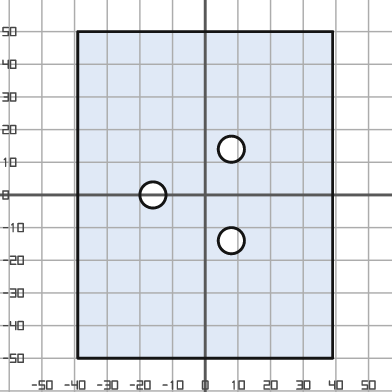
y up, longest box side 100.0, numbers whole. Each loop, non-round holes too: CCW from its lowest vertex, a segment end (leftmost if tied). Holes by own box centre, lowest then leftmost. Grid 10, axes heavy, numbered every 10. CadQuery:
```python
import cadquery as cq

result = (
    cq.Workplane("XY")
    .moveTo(-39.0, -50.0)
    .lineTo(39.0, -50.0)
    .lineTo(39.0, 50.0)
    .lineTo(-39.0, 50.0)
    .close()
    .moveTo(8.0, -14.0)
    .circle(4.0)
    .moveTo(-16.0, 0.0)
    .circle(4.0)
    .moveTo(8.0, 14.0)
    .circle(4.0)
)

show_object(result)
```